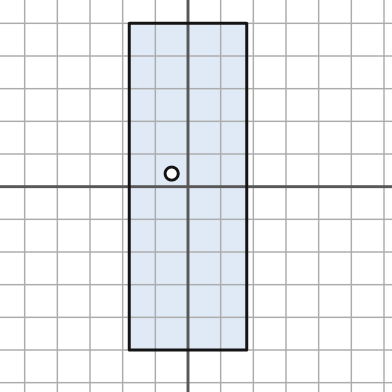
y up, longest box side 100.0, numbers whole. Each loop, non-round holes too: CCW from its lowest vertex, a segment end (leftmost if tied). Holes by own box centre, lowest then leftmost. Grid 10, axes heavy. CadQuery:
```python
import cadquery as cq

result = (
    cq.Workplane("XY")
    .moveTo(-18.0, -50.0)
    .lineTo(18.0, -50.0)
    .lineTo(18.0, 50.0)
    .lineTo(-18.0, 50.0)
    .close()
    .moveTo(-5.0, 4.0)
    .circle(2.0)
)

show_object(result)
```